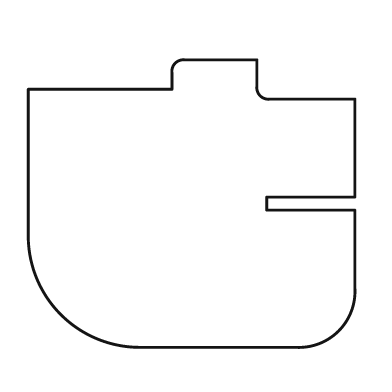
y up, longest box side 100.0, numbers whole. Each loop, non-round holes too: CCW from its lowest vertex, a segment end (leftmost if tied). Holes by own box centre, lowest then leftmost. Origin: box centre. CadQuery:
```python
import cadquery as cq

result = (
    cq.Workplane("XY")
    .moveTo(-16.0, -44.0)
    .lineTo(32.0, -44.0)
    .threePointArc((45.0, -39.0), (50.0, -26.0))
    .lineTo(50.0, -2.0)
    .lineTo(23.0, -2.0)
    .lineTo(23.0, 2.0)
    .lineTo(50.0, 2.0)
    .lineTo(50.0, 32.0)
    .lineTo(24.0, 32.0)
    .threePointArc((21.0, 33.0), (20.0, 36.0))
    .lineTo(20.0, 44.0)
    .lineTo(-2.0, 44.0)
    .threePointArc((-5.0, 43.0), (-6.0, 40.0))
    .lineTo(-6.0, 35.0)
    .lineTo(-50.0, 35.0)
    .lineTo(-50.0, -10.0)
    .threePointArc((-40.0, -34.0), (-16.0, -44.0))
    .close()
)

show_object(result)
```